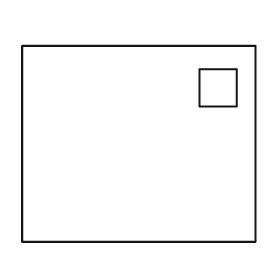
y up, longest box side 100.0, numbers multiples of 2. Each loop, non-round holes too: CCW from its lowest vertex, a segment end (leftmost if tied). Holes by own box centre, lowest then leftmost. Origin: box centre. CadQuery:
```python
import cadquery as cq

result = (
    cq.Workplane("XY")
    .moveTo(-50.0, -42.0)
    .lineTo(50.0, -42.0)
    .lineTo(50.0, 42.0)
    .lineTo(-50.0, 42.0)
    .close()
    .moveTo(26.0, 16.0)
    .lineTo(42.0, 16.0)
    .lineTo(42.0, 32.0)
    .lineTo(26.0, 32.0)
    .close()
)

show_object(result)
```